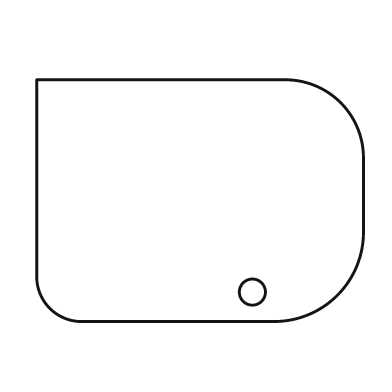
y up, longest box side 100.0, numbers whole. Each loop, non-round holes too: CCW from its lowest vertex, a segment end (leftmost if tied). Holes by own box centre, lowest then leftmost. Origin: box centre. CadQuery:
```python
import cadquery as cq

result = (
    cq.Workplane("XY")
    .moveTo(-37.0, -37.0)
    .lineTo(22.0, -37.0)
    .threePointArc((42.0, -29.0), (50.0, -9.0))
    .lineTo(50.0, 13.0)
    .threePointArc((43.0, 30.0), (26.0, 37.0))
    .lineTo(-50.0, 37.0)
    .lineTo(-50.0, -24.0)
    .threePointArc((-46.0, -33.0), (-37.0, -37.0))
    .close()
    .moveTo(16.0, -28.0)
    .circle(4.0)
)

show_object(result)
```